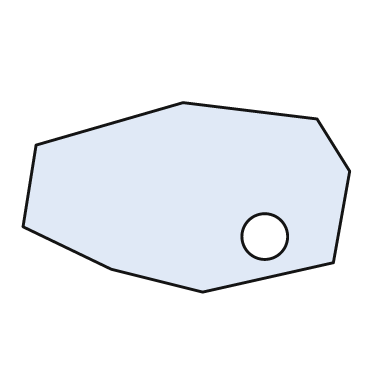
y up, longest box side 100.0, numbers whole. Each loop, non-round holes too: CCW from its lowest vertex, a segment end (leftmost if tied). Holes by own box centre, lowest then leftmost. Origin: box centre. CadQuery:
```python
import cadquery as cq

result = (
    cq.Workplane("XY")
    .moveTo(5.0, -29.0)
    .lineTo(45.0, -20.0)
    .lineTo(50.0, 8.0)
    .lineTo(40.0, 24.0)
    .lineTo(-1.0, 29.0)
    .lineTo(-46.0, 16.0)
    .lineTo(-50.0, -9.0)
    .lineTo(-23.0, -22.0)
    .close()
    .moveTo(24.0, -12.0)
    .circle(7.0)
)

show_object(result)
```